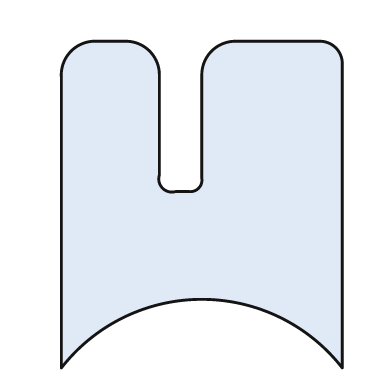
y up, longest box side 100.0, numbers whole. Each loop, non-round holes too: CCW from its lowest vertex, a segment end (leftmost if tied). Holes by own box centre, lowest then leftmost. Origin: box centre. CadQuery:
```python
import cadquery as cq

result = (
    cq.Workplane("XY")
    .moveTo(-43.0, -50.0)
    .threePointArc((0.0, -29.0), (43.0, -50.0))
    .lineTo(43.0, 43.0)
    .threePointArc((41.0, 48.0), (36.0, 50.0))
    .lineTo(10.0, 50.0)
    .threePointArc((3.0, 47.0), (0.0, 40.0))
    .lineTo(0.0, 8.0)
    .threePointArc((-1.0, 5.0), (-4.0, 4.0))
    .lineTo(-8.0, 4.0)
    .threePointArc((-12.0, 5.0), (-13.0, 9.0))
    .lineTo(-13.0, 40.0)
    .threePointArc((-16.0, 47.0), (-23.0, 50.0))
    .lineTo(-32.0, 50.0)
    .threePointArc((-40.0, 47.0), (-43.0, 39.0))
    .close()
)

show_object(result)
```